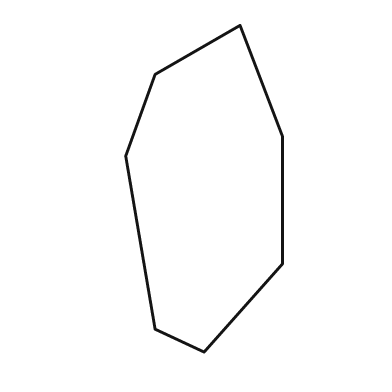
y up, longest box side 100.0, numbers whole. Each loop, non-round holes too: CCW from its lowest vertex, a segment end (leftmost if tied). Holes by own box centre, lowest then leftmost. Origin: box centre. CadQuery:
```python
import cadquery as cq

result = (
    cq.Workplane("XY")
    .moveTo(0.0, -50.0)
    .lineTo(24.0, -23.0)
    .lineTo(24.0, 16.0)
    .lineTo(11.0, 50.0)
    .lineTo(-15.0, 35.0)
    .lineTo(-24.0, 10.0)
    .lineTo(-15.0, -43.0)
    .close()
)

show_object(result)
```